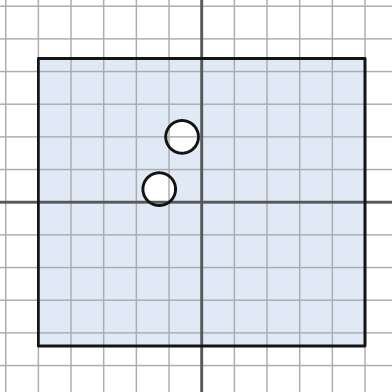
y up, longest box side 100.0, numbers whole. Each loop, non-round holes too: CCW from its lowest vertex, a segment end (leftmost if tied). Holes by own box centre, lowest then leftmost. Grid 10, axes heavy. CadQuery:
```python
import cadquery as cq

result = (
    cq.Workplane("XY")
    .moveTo(-50.0, -44.0)
    .lineTo(50.0, -44.0)
    .lineTo(50.0, 44.0)
    .lineTo(-50.0, 44.0)
    .close()
    .moveTo(-13.0, 4.0)
    .circle(5.0)
    .moveTo(-6.0, 20.0)
    .circle(5.0)
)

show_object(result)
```